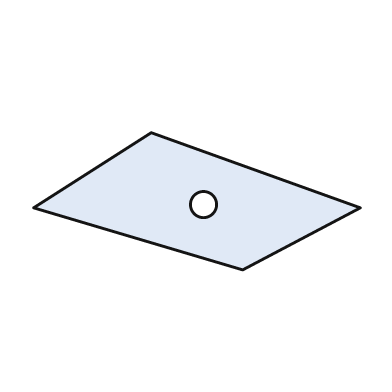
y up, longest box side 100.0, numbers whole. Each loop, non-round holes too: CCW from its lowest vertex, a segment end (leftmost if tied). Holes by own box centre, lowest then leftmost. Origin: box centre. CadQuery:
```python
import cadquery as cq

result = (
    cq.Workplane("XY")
    .moveTo(14.0, -21.0)
    .lineTo(50.0, -2.0)
    .lineTo(-14.0, 21.0)
    .lineTo(-50.0, -2.0)
    .close()
    .moveTo(2.0, -1.0)
    .circle(4.0)
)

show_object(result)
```